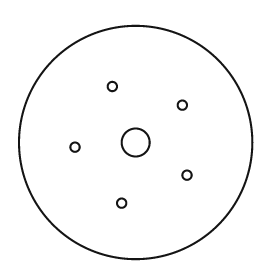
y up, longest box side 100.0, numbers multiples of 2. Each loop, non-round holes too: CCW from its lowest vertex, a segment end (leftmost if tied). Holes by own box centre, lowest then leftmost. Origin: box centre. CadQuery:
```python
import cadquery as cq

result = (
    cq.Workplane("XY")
    .moveTo(0.0, 0.0)
    .circle(50.0)
    .moveTo(-6.0, -26.0)
    .circle(2.0)
    .moveTo(22.0, -14.0)
    .circle(2.0)
    .moveTo(-26.0, -2.0)
    .circle(2.0)
    .moveTo(0.0, 0.0)
    .circle(6.0)
    .moveTo(20.0, 16.0)
    .circle(2.0)
    .moveTo(-10.0, 24.0)
    .circle(2.0)
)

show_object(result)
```